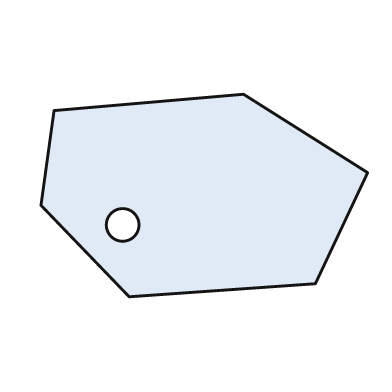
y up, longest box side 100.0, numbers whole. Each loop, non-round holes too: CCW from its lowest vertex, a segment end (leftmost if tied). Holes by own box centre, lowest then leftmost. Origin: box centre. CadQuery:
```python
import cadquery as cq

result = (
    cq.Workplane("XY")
    .moveTo(-23.0, -31.0)
    .lineTo(34.0, -27.0)
    .lineTo(50.0, 7.0)
    .lineTo(12.0, 31.0)
    .lineTo(-46.0, 26.0)
    .lineTo(-50.0, -3.0)
    .close()
    .moveTo(-25.0, -9.0)
    .circle(5.0)
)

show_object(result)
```